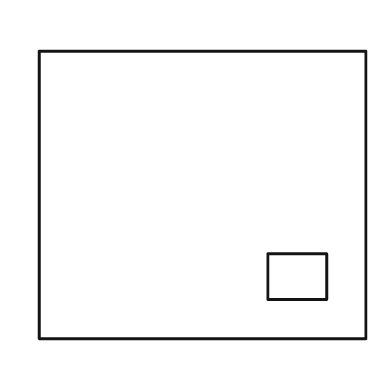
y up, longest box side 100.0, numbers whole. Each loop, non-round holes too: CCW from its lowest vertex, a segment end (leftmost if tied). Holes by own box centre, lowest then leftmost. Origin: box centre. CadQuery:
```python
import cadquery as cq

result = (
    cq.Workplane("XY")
    .moveTo(-50.0, -44.0)
    .lineTo(50.0, -44.0)
    .lineTo(50.0, 44.0)
    .lineTo(-50.0, 44.0)
    .close()
    .moveTo(20.0, -32.0)
    .lineTo(38.0, -32.0)
    .lineTo(38.0, -18.0)
    .lineTo(20.0, -18.0)
    .close()
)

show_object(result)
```